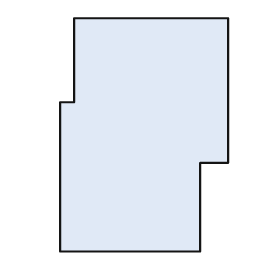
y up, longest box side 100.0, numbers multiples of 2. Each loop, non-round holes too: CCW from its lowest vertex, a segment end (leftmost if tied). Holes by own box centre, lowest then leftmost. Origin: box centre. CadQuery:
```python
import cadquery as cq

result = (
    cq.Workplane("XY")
    .moveTo(-36.0, -50.0)
    .lineTo(24.0, -50.0)
    .lineTo(24.0, -12.0)
    .lineTo(36.0, -12.0)
    .lineTo(36.0, 50.0)
    .lineTo(-30.0, 50.0)
    .lineTo(-30.0, 14.0)
    .lineTo(-36.0, 14.0)
    .close()
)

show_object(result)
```